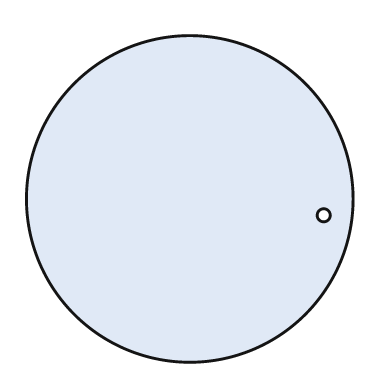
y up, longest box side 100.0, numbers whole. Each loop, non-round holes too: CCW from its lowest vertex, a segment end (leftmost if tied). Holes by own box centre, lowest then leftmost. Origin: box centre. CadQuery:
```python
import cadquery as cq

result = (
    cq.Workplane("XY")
    .moveTo(0.0, 0.0)
    .circle(50.0)
    .moveTo(41.0, -5.0)
    .circle(2.0)
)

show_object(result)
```